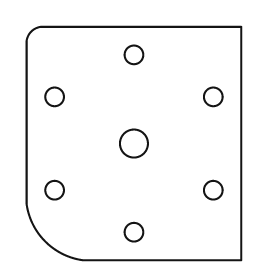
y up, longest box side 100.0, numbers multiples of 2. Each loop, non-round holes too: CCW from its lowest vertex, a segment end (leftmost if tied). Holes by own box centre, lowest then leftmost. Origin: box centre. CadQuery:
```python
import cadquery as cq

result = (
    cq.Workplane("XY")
    .moveTo(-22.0, -50.0)
    .lineTo(46.0, -50.0)
    .lineTo(46.0, 50.0)
    .lineTo(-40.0, 50.0)
    .threePointArc((-44.0, 48.0), (-46.0, 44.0))
    .lineTo(-46.0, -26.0)
    .threePointArc((-38.0, -42.0), (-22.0, -50.0))
    .close()
    .moveTo(0.0, -38.0)
    .circle(4.0)
    .moveTo(-34.0, -20.0)
    .circle(4.0)
    .moveTo(34.0, -20.0)
    .circle(4.0)
    .moveTo(0.0, 0.0)
    .circle(6.0)
    .moveTo(-34.0, 20.0)
    .circle(4.0)
    .moveTo(34.0, 20.0)
    .circle(4.0)
    .moveTo(0.0, 38.0)
    .circle(4.0)
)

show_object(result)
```